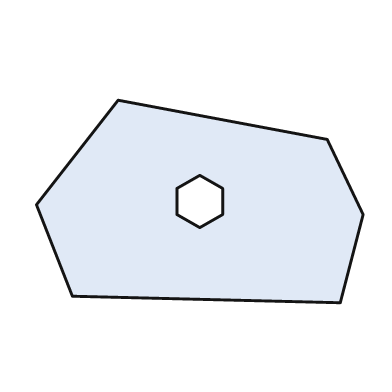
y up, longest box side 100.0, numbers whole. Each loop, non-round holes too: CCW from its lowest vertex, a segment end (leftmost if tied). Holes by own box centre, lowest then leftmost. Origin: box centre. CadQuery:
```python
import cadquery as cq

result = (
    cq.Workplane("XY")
    .moveTo(43.0, -31.0)
    .lineTo(50.0, -4.0)
    .lineTo(39.0, 19.0)
    .lineTo(-25.0, 31.0)
    .lineTo(-50.0, -1.0)
    .lineTo(-39.0, -29.0)
    .close()
    .moveTo(0.0, -8.0)
    .lineTo(7.0, -4.0)
    .lineTo(7.0, 4.0)
    .lineTo(0.0, 8.0)
    .lineTo(-7.0, 4.0)
    .lineTo(-7.0, -4.0)
    .close()
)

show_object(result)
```